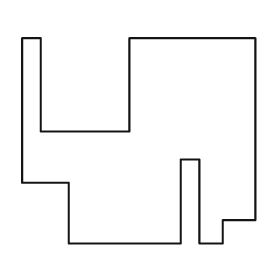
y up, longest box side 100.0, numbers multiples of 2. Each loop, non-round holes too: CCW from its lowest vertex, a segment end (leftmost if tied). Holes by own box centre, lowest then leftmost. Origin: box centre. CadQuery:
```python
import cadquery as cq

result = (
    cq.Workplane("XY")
    .moveTo(-30.0, -44.0)
    .lineTo(18.0, -44.0)
    .lineTo(18.0, -8.0)
    .lineTo(26.0, -8.0)
    .lineTo(26.0, -44.0)
    .lineTo(36.0, -44.0)
    .lineTo(36.0, -34.0)
    .lineTo(50.0, -34.0)
    .lineTo(50.0, 44.0)
    .lineTo(-4.0, 44.0)
    .lineTo(-4.0, 4.0)
    .lineTo(-42.0, 4.0)
    .lineTo(-42.0, 44.0)
    .lineTo(-50.0, 44.0)
    .lineTo(-50.0, -18.0)
    .lineTo(-30.0, -18.0)
    .close()
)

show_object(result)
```